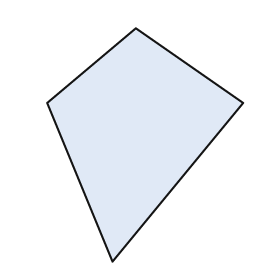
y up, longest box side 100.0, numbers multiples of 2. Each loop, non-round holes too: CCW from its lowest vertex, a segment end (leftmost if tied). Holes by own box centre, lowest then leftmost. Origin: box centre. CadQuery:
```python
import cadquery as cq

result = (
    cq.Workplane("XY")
    .moveTo(-14.0, -50.0)
    .lineTo(42.0, 18.0)
    .lineTo(-4.0, 50.0)
    .lineTo(-42.0, 18.0)
    .close()
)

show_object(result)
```